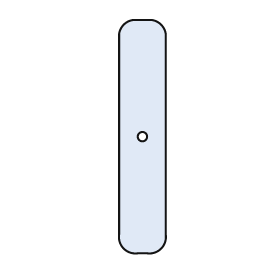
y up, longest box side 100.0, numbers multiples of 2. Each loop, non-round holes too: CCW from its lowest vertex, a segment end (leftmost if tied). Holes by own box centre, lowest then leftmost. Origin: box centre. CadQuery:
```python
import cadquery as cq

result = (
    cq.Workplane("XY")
    .moveTo(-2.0, -50.0)
    .lineTo(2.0, -50.0)
    .threePointArc((8.0, -48.0), (10.0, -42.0))
    .lineTo(10.0, 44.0)
    .threePointArc((8.0, 48.0), (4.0, 50.0))
    .lineTo(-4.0, 50.0)
    .threePointArc((-8.0, 48.0), (-10.0, 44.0))
    .lineTo(-10.0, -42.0)
    .threePointArc((-8.0, -48.0), (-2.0, -50.0))
    .close()
    .moveTo(0.0, 0.0)
    .circle(2.0)
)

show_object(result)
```